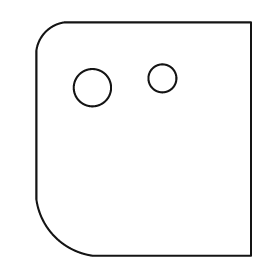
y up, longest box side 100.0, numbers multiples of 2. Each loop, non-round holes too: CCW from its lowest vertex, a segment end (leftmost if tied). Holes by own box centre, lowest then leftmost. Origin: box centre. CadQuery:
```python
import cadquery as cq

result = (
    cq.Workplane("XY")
    .moveTo(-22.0, -50.0)
    .lineTo(46.0, -50.0)
    .lineTo(46.0, 50.0)
    .lineTo(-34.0, 50.0)
    .threePointArc((-42.0, 46.0), (-46.0, 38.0))
    .lineTo(-46.0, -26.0)
    .threePointArc((-38.0, -42.0), (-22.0, -50.0))
    .close()
    .moveTo(-22.0, 22.0)
    .circle(8.0)
    .moveTo(8.0, 26.0)
    .circle(6.0)
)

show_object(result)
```